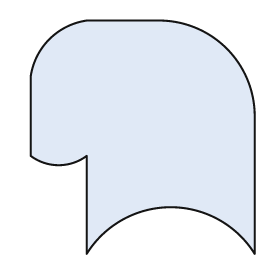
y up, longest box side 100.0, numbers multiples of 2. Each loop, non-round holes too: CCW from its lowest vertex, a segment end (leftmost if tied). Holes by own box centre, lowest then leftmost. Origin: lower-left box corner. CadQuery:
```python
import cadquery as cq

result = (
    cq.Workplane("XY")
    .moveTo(24.0, 0.0)
    .threePointArc((60.0, 20.0), (96.0, 0.0))
    .lineTo(96.0, 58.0)
    .threePointArc((84.0, 88.0), (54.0, 100.0))
    .lineTo(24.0, 100.0)
    .threePointArc((8.0, 92.0), (0.0, 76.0))
    .lineTo(0.0, 42.0)
    .threePointArc((12.0, 38.0), (24.0, 42.0))
    .close()
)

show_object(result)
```